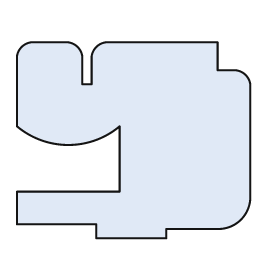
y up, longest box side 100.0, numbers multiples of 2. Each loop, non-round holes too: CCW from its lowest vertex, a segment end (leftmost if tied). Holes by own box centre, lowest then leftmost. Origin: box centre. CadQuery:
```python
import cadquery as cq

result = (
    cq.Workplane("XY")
    .moveTo(-16.0, -42.0)
    .lineTo(14.0, -42.0)
    .lineTo(14.0, -38.0)
    .lineTo(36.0, -38.0)
    .threePointArc((46.0, -34.0), (50.0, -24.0))
    .lineTo(50.0, 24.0)
    .threePointArc((48.0, 28.0), (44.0, 30.0))
    .lineTo(36.0, 30.0)
    .lineTo(36.0, 42.0)
    .lineTo(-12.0, 42.0)
    .threePointArc((-16.0, 40.0), (-18.0, 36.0))
    .lineTo(-18.0, 24.0)
    .lineTo(-22.0, 24.0)
    .lineTo(-22.0, 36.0)
    .threePointArc((-24.0, 40.0), (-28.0, 42.0))
    .lineTo(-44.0, 42.0)
    .threePointArc((-48.0, 40.0), (-50.0, 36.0))
    .lineTo(-50.0, 6.0)
    .threePointArc((-28.0, -2.0), (-6.0, 6.0))
    .lineTo(-6.0, -22.0)
    .lineTo(-50.0, -22.0)
    .lineTo(-50.0, -36.0)
    .lineTo(-16.0, -36.0)
    .close()
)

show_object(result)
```